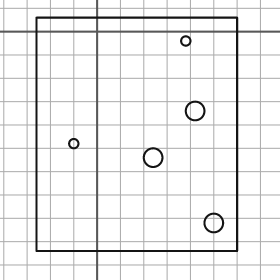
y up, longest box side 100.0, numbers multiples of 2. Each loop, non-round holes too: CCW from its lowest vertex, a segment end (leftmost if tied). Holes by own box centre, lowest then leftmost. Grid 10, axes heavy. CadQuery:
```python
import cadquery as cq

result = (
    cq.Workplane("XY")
    .moveTo(-26.0, -94.0)
    .lineTo(60.0, -94.0)
    .lineTo(60.0, 6.0)
    .lineTo(-26.0, 6.0)
    .close()
    .moveTo(50.0, -82.0)
    .circle(4.0)
    .moveTo(24.0, -54.0)
    .circle(4.0)
    .moveTo(-10.0, -48.0)
    .circle(2.0)
    .moveTo(42.0, -34.0)
    .circle(4.0)
    .moveTo(38.0, -4.0)
    .circle(2.0)
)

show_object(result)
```